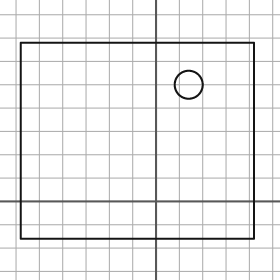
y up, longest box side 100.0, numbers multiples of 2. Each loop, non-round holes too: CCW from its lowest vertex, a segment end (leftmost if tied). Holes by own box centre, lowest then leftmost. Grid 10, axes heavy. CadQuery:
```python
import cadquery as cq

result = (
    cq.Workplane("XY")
    .moveTo(-58.0, -16.0)
    .lineTo(42.0, -16.0)
    .lineTo(42.0, 68.0)
    .lineTo(-58.0, 68.0)
    .close()
    .moveTo(14.0, 50.0)
    .circle(6.0)
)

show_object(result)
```